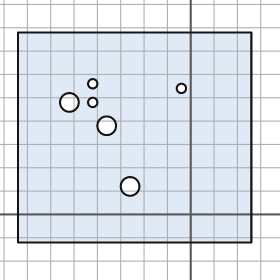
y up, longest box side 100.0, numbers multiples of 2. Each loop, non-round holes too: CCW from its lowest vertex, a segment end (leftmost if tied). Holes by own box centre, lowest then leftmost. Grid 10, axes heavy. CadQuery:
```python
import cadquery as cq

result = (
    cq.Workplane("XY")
    .moveTo(-74.0, -12.0)
    .lineTo(26.0, -12.0)
    .lineTo(26.0, 78.0)
    .lineTo(-74.0, 78.0)
    .close()
    .moveTo(-26.0, 12.0)
    .circle(4.0)
    .moveTo(-36.0, 38.0)
    .circle(4.0)
    .moveTo(-52.0, 48.0)
    .circle(4.0)
    .moveTo(-42.0, 48.0)
    .circle(2.0)
    .moveTo(-4.0, 54.0)
    .circle(2.0)
    .moveTo(-42.0, 56.0)
    .circle(2.0)
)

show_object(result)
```